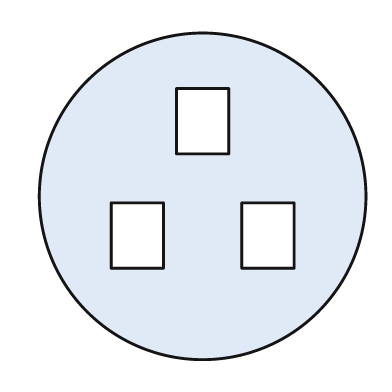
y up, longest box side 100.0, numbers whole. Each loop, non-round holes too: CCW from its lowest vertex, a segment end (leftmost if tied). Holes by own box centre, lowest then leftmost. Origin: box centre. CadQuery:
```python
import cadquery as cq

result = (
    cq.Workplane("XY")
    .moveTo(0.0, 0.0)
    .circle(50.0)
    .moveTo(-28.0, -22.0)
    .lineTo(-12.0, -22.0)
    .lineTo(-12.0, -2.0)
    .lineTo(-28.0, -2.0)
    .close()
    .moveTo(12.0, -22.0)
    .lineTo(28.0, -22.0)
    .lineTo(28.0, -2.0)
    .lineTo(12.0, -2.0)
    .close()
    .moveTo(-8.0, 13.0)
    .lineTo(8.0, 13.0)
    .lineTo(8.0, 33.0)
    .lineTo(-8.0, 33.0)
    .close()
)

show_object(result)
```